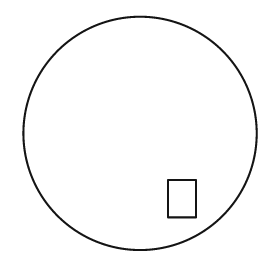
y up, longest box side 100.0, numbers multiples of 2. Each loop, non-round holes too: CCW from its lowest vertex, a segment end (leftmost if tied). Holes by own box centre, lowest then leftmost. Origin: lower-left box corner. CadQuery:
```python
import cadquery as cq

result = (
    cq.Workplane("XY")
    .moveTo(50.0, 50.0)
    .circle(50.0)
    .moveTo(62.0, 14.0)
    .lineTo(74.0, 14.0)
    .lineTo(74.0, 30.0)
    .lineTo(62.0, 30.0)
    .close()
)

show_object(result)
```